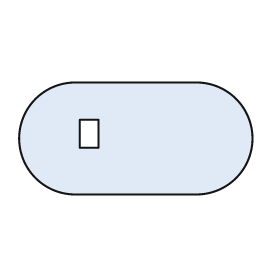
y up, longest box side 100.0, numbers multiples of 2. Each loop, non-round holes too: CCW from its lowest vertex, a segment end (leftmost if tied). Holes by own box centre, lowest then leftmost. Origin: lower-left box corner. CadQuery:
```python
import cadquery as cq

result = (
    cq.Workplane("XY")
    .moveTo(24.0, 0.0)
    .lineTo(76.0, 0.0)
    .threePointArc((100.0, 24.0), (76.0, 48.0))
    .lineTo(24.0, 48.0)
    .threePointArc((0.0, 24.0), (24.0, 0.0))
    .close()
    .moveTo(26.0, 20.0)
    .lineTo(34.0, 20.0)
    .lineTo(34.0, 32.0)
    .lineTo(26.0, 32.0)
    .close()
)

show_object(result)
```